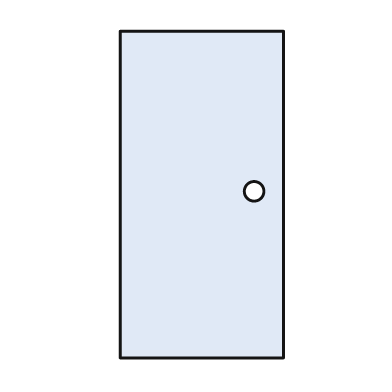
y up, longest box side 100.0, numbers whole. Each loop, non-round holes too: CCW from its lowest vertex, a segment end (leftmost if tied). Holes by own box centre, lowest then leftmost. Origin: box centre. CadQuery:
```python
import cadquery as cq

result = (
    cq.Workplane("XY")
    .moveTo(-25.0, -50.0)
    .lineTo(25.0, -50.0)
    .lineTo(25.0, 50.0)
    .lineTo(-25.0, 50.0)
    .close()
    .moveTo(16.0, 1.0)
    .circle(3.0)
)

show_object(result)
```